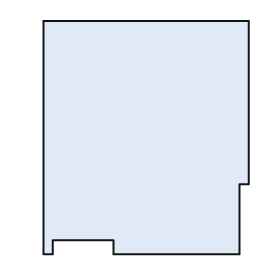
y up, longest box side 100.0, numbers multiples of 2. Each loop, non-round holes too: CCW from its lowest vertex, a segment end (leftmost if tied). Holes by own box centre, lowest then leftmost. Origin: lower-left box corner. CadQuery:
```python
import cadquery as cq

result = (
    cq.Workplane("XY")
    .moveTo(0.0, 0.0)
    .lineTo(4.0, 0.0)
    .lineTo(4.0, 6.0)
    .lineTo(30.0, 6.0)
    .lineTo(30.0, 0.0)
    .lineTo(84.0, 0.0)
    .lineTo(84.0, 30.0)
    .lineTo(88.0, 30.0)
    .lineTo(88.0, 100.0)
    .lineTo(0.0, 100.0)
    .close()
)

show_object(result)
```